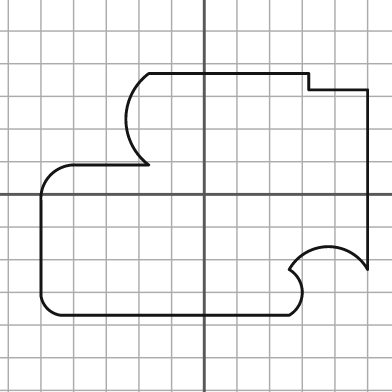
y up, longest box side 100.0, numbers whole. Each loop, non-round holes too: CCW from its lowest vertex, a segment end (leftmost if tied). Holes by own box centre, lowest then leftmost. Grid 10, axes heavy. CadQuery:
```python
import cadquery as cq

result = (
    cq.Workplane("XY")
    .moveTo(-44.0, -37.0)
    .lineTo(26.0, -37.0)
    .threePointArc((30.0, -30.0), (26.0, -23.0))
    .threePointArc((38.0, -16.0), (50.0, -23.0))
    .lineTo(50.0, 32.0)
    .lineTo(32.0, 32.0)
    .lineTo(32.0, 37.0)
    .lineTo(-17.0, 37.0)
    .threePointArc((-24.0, 23.0), (-17.0, 9.0))
    .lineTo(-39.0, 9.0)
    .threePointArc((-47.0, 6.0), (-50.0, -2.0))
    .lineTo(-50.0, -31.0)
    .threePointArc((-48.0, -35.0), (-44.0, -37.0))
    .close()
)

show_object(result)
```